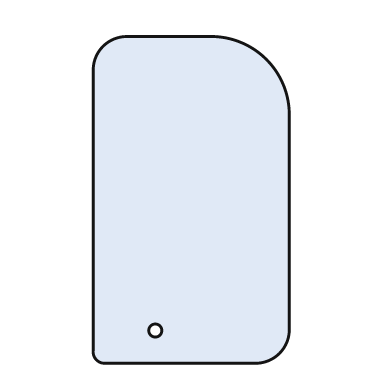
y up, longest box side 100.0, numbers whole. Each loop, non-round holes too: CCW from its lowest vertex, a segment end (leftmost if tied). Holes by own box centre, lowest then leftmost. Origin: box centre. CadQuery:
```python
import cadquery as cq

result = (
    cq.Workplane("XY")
    .moveTo(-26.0, -50.0)
    .lineTo(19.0, -50.0)
    .threePointArc((27.0, -47.0), (30.0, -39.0))
    .lineTo(30.0, 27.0)
    .threePointArc((23.0, 43.0), (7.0, 50.0))
    .lineTo(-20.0, 50.0)
    .threePointArc((-27.0, 47.0), (-30.0, 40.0))
    .lineTo(-30.0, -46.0)
    .threePointArc((-29.0, -49.0), (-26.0, -50.0))
    .close()
    .moveTo(-11.0, -40.0)
    .circle(2.0)
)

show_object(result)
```